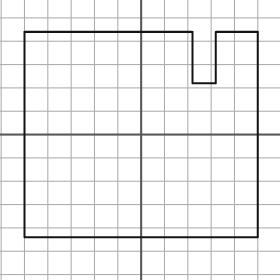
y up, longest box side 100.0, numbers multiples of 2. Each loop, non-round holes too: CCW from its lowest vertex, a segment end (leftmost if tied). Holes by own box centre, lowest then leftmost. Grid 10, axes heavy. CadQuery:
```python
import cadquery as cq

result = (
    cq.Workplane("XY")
    .moveTo(-50.0, -44.0)
    .lineTo(50.0, -44.0)
    .lineTo(50.0, 44.0)
    .lineTo(32.0, 44.0)
    .lineTo(32.0, 22.0)
    .lineTo(22.0, 22.0)
    .lineTo(22.0, 44.0)
    .lineTo(-50.0, 44.0)
    .close()
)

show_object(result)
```